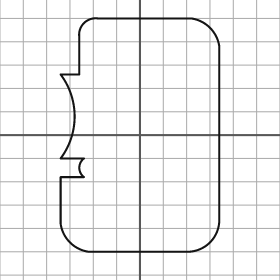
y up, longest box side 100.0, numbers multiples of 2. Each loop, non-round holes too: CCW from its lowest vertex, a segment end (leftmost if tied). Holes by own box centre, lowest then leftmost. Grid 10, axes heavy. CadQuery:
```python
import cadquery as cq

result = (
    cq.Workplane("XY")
    .moveTo(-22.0, -50.0)
    .lineTo(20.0, -50.0)
    .threePointArc((30.0, -46.0), (34.0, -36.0))
    .lineTo(34.0, 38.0)
    .threePointArc((30.0, 46.0), (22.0, 50.0))
    .lineTo(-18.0, 50.0)
    .threePointArc((-24.0, 48.0), (-26.0, 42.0))
    .lineTo(-26.0, 26.0)
    .lineTo(-34.0, 26.0)
    .threePointArc((-28.0, 8.0), (-34.0, -10.0))
    .lineTo(-24.0, -10.0)
    .threePointArc((-26.0, -14.0), (-24.0, -18.0))
    .lineTo(-34.0, -18.0)
    .lineTo(-34.0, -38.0)
    .threePointArc((-30.0, -46.0), (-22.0, -50.0))
    .close()
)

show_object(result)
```